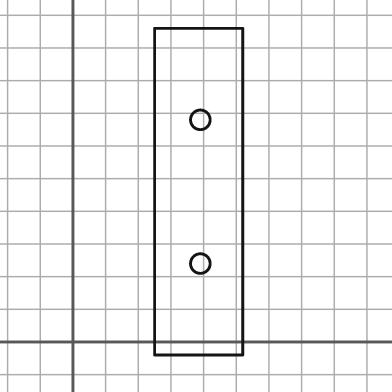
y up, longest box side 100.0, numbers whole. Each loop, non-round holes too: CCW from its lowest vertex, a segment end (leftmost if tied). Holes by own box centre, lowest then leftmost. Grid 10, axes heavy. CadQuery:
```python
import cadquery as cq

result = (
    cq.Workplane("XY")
    .moveTo(25.0, -4.0)
    .lineTo(52.0, -4.0)
    .lineTo(52.0, 96.0)
    .lineTo(25.0, 96.0)
    .close()
    .moveTo(39.0, 24.0)
    .circle(3.0)
    .moveTo(39.0, 68.0)
    .circle(3.0)
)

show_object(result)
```